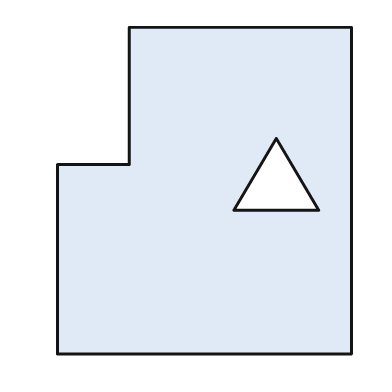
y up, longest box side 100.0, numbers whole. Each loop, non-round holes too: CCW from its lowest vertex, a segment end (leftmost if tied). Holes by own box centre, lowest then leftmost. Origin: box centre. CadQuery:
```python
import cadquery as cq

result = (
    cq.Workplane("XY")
    .moveTo(-45.0, -50.0)
    .lineTo(45.0, -50.0)
    .lineTo(45.0, 50.0)
    .lineTo(-23.0, 50.0)
    .lineTo(-23.0, 8.0)
    .lineTo(-45.0, 8.0)
    .close()
    .moveTo(9.0, -6.0)
    .lineTo(35.0, -6.0)
    .lineTo(22.0, 16.0)
    .close()
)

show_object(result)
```